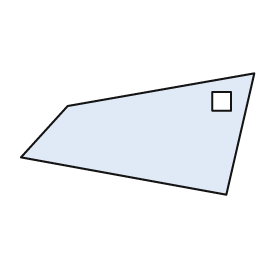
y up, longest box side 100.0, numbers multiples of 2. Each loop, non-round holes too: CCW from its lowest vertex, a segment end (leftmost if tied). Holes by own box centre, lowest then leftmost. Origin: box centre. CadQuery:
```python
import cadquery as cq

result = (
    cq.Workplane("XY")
    .moveTo(38.0, -26.0)
    .lineTo(50.0, 26.0)
    .lineTo(-30.0, 12.0)
    .lineTo(-50.0, -10.0)
    .close()
    .moveTo(32.0, 10.0)
    .lineTo(40.0, 10.0)
    .lineTo(40.0, 18.0)
    .lineTo(32.0, 18.0)
    .close()
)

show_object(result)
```